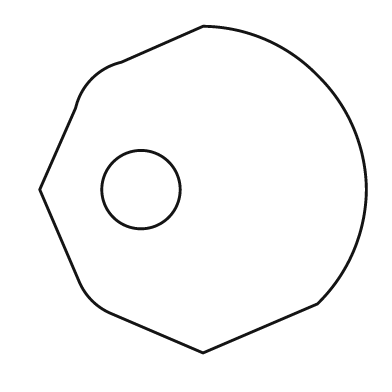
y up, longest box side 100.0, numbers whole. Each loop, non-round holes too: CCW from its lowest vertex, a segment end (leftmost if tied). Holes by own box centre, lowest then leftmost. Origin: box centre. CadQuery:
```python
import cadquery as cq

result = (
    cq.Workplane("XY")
    .moveTo(0.0, -50.0)
    .lineTo(35.0, -35.0)
    .threePointArc((46.0, -19.0), (50.0, 0.0))
    .threePointArc((46.0, 19.0), (35.0, 35.0))
    .threePointArc((19.0, 46.0), (0.0, 50.0))
    .lineTo(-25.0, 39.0)
    .threePointArc((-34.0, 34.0), (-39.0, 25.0))
    .lineTo(-50.0, 0.0)
    .lineTo(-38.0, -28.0)
    .threePointArc((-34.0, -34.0), (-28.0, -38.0))
    .close()
    .moveTo(-19.0, 0.0)
    .circle(12.0)
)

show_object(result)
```